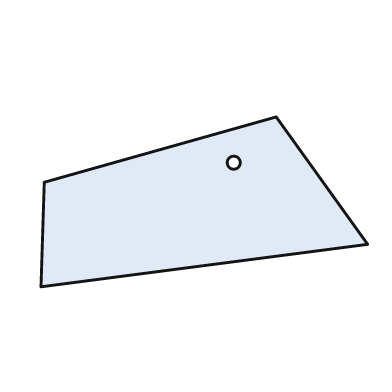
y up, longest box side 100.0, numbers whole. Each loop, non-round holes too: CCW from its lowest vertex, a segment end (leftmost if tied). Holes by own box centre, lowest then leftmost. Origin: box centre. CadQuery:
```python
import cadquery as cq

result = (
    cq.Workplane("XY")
    .moveTo(-50.0, -26.0)
    .lineTo(50.0, -13.0)
    .lineTo(22.0, 26.0)
    .lineTo(-49.0, 6.0)
    .close()
    .moveTo(9.0, 12.0)
    .circle(2.0)
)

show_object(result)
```